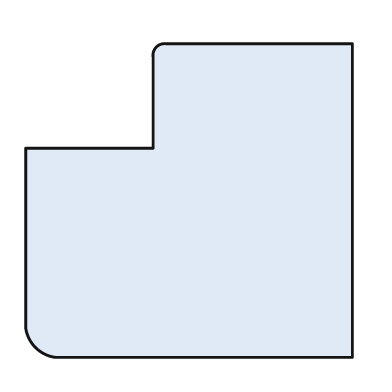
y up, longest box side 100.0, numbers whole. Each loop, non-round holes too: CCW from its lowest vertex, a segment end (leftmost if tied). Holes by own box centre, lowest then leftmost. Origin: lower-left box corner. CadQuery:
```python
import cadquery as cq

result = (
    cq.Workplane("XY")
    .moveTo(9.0, 0.0)
    .lineTo(100.0, 0.0)
    .lineTo(100.0, 96.0)
    .lineTo(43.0, 96.0)
    .threePointArc((40.0, 95.0), (39.0, 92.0))
    .lineTo(39.0, 64.0)
    .lineTo(0.0, 64.0)
    .lineTo(0.0, 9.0)
    .threePointArc((3.0, 3.0), (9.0, 0.0))
    .close()
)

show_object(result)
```